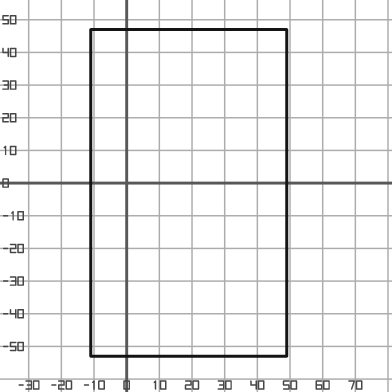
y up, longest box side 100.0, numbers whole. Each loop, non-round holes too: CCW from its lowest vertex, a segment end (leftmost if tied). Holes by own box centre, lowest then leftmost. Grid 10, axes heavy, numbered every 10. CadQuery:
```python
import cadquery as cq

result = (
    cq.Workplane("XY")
    .moveTo(-11.0, -53.0)
    .lineTo(49.0, -53.0)
    .lineTo(49.0, 47.0)
    .lineTo(-11.0, 47.0)
    .close()
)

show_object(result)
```